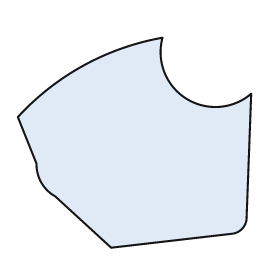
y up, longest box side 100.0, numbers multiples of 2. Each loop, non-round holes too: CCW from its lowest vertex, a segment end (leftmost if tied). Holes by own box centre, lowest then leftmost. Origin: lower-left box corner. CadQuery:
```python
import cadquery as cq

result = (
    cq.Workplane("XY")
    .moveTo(40.0, 0.0)
    .lineTo(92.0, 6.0)
    .threePointArc((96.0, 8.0), (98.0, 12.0))
    .lineTo(100.0, 66.0)
    .threePointArc((72.0, 64.0), (62.0, 90.0))
    .threePointArc((28.0, 78.0), (0.0, 56.0))
    .lineTo(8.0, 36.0)
    .threePointArc((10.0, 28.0), (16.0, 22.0))
    .close()
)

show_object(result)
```